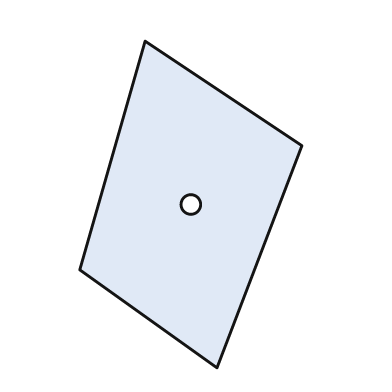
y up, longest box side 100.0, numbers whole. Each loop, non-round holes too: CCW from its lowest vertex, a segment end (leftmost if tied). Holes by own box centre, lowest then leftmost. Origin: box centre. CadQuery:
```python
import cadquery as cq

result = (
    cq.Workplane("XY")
    .moveTo(8.0, -50.0)
    .lineTo(34.0, 18.0)
    .lineTo(-14.0, 50.0)
    .lineTo(-34.0, -20.0)
    .close()
    .moveTo(0.0, 0.0)
    .circle(3.0)
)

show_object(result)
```